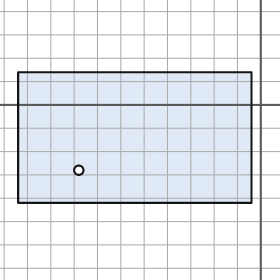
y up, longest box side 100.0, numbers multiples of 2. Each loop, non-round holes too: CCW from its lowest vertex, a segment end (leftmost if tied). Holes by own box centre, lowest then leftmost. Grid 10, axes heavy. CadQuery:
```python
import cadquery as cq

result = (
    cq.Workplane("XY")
    .moveTo(-104.0, -42.0)
    .lineTo(-4.0, -42.0)
    .lineTo(-4.0, 14.0)
    .lineTo(-104.0, 14.0)
    .close()
    .moveTo(-78.0, -28.0)
    .circle(2.0)
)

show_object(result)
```